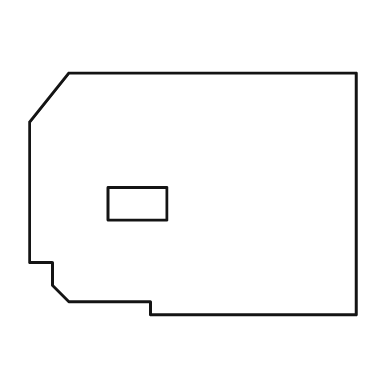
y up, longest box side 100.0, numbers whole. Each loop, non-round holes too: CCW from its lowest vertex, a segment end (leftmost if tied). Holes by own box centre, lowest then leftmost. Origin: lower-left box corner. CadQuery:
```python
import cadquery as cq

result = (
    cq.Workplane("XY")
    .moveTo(37.0, 0.0)
    .lineTo(100.0, 0.0)
    .lineTo(100.0, 74.0)
    .lineTo(12.0, 74.0)
    .lineTo(0.0, 59.0)
    .lineTo(0.0, 16.0)
    .lineTo(7.0, 16.0)
    .lineTo(7.0, 9.0)
    .lineTo(12.0, 4.0)
    .lineTo(37.0, 4.0)
    .close()
    .moveTo(24.0, 29.0)
    .lineTo(42.0, 29.0)
    .lineTo(42.0, 39.0)
    .lineTo(24.0, 39.0)
    .close()
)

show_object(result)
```